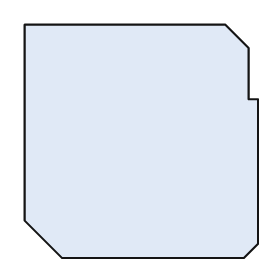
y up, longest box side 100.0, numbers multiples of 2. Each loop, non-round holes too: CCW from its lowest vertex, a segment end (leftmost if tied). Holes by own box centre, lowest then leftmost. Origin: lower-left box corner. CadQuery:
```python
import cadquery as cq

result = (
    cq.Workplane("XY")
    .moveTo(16.0, 0.0)
    .lineTo(94.0, 0.0)
    .lineTo(100.0, 6.0)
    .lineTo(100.0, 68.0)
    .lineTo(96.0, 68.0)
    .lineTo(96.0, 90.0)
    .lineTo(86.0, 100.0)
    .lineTo(0.0, 100.0)
    .lineTo(0.0, 16.0)
    .close()
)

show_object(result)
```